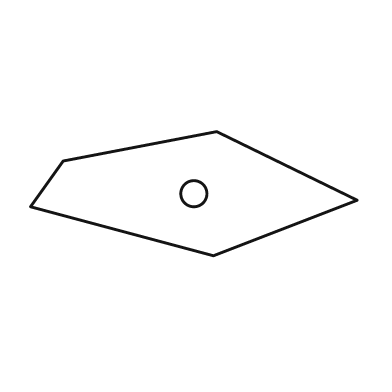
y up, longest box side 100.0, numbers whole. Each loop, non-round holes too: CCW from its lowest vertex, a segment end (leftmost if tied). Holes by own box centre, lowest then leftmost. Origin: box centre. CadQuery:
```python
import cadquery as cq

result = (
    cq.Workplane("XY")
    .moveTo(6.0, -19.0)
    .lineTo(50.0, -2.0)
    .lineTo(7.0, 19.0)
    .lineTo(-40.0, 10.0)
    .lineTo(-50.0, -4.0)
    .close()
    .moveTo(0.0, 0.0)
    .circle(4.0)
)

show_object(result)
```